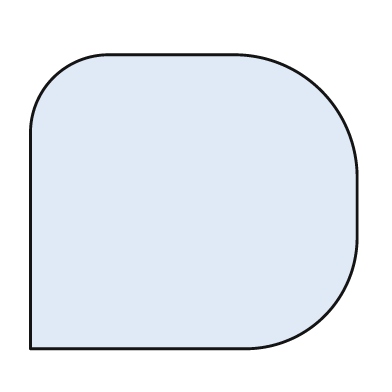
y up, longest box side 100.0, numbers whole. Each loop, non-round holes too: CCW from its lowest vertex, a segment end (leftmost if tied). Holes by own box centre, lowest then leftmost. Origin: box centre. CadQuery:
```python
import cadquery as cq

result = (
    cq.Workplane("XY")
    .moveTo(-50.0, -45.0)
    .lineTo(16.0, -45.0)
    .threePointArc((40.0, -35.0), (50.0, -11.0))
    .lineTo(50.0, 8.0)
    .threePointArc((39.0, 34.0), (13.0, 45.0))
    .lineTo(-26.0, 45.0)
    .threePointArc((-43.0, 38.0), (-50.0, 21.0))
    .close()
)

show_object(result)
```